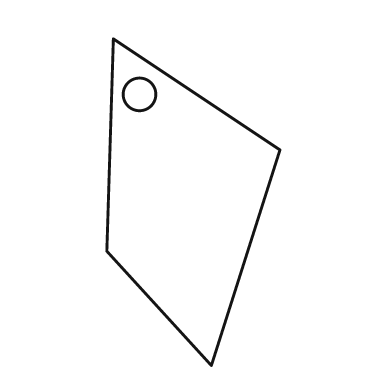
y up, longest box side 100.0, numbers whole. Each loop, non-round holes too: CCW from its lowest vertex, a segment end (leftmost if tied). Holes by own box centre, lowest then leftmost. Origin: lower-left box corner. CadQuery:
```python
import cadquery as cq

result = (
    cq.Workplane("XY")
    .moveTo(32.0, 0.0)
    .lineTo(53.0, 66.0)
    .lineTo(2.0, 100.0)
    .lineTo(0.0, 35.0)
    .close()
    .moveTo(10.0, 83.0)
    .circle(5.0)
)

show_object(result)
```